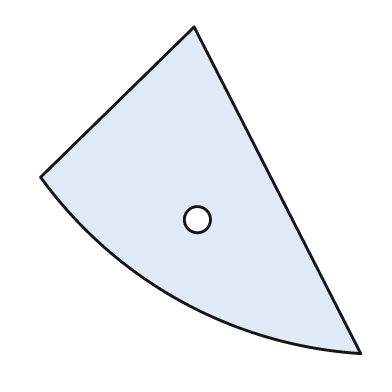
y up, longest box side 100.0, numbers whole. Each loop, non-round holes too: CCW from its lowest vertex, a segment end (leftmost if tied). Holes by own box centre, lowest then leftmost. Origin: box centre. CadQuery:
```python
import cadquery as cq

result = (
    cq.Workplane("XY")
    .moveTo(49.0, -50.0)
    .lineTo(-2.0, 50.0)
    .lineTo(-49.0, 4.0)
    .threePointArc((-6.0, -34.0), (49.0, -50.0))
    .close()
    .moveTo(-1.0, -9.0)
    .circle(4.0)
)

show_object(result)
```